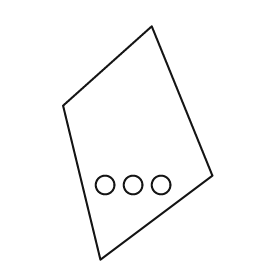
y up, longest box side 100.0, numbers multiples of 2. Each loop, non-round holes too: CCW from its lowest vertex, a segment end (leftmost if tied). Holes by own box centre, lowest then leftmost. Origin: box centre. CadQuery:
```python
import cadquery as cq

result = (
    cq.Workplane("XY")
    .moveTo(-16.0, -50.0)
    .lineTo(32.0, -14.0)
    .lineTo(6.0, 50.0)
    .lineTo(-32.0, 16.0)
    .close()
    .moveTo(-14.0, -18.0)
    .circle(4.0)
    .moveTo(-2.0, -18.0)
    .circle(4.0)
    .moveTo(10.0, -18.0)
    .circle(4.0)
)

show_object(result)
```